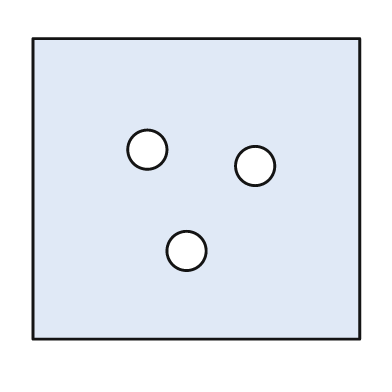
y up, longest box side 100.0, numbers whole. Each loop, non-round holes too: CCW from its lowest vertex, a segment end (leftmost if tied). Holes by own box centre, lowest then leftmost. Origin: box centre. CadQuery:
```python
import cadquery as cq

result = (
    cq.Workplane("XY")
    .moveTo(-50.0, -46.0)
    .lineTo(50.0, -46.0)
    .lineTo(50.0, 46.0)
    .lineTo(-50.0, 46.0)
    .close()
    .moveTo(-3.0, -19.0)
    .circle(6.0)
    .moveTo(18.0, 7.0)
    .circle(6.0)
    .moveTo(-15.0, 12.0)
    .circle(6.0)
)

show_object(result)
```